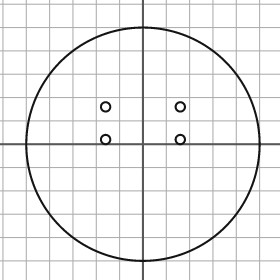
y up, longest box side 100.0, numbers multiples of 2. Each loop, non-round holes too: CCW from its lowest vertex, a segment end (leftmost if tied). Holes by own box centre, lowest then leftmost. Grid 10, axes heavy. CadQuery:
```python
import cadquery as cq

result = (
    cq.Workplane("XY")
    .moveTo(0.0, 0.0)
    .circle(50.0)
    .moveTo(-16.0, 2.0)
    .circle(2.0)
    .moveTo(16.0, 2.0)
    .circle(2.0)
    .moveTo(-16.0, 16.0)
    .circle(2.0)
    .moveTo(16.0, 16.0)
    .circle(2.0)
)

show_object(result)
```